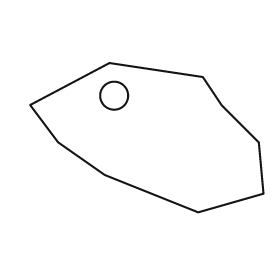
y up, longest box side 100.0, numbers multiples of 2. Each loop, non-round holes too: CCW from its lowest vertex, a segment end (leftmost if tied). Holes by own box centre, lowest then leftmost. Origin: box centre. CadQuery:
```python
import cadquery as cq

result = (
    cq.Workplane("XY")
    .moveTo(22.0, -32.0)
    .lineTo(50.0, -24.0)
    .lineTo(48.0, -2.0)
    .lineTo(32.0, 14.0)
    .lineTo(24.0, 26.0)
    .lineTo(-16.0, 32.0)
    .lineTo(-50.0, 14.0)
    .lineTo(-38.0, -2.0)
    .lineTo(-18.0, -16.0)
    .close()
    .moveTo(-14.0, 18.0)
    .circle(6.0)
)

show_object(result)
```